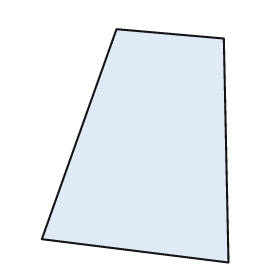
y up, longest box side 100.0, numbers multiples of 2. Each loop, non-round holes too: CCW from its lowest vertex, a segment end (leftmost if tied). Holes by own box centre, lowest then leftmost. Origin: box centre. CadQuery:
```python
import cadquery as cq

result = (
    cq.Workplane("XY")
    .moveTo(40.0, -50.0)
    .lineTo(38.0, 46.0)
    .lineTo(-8.0, 50.0)
    .lineTo(-40.0, -40.0)
    .close()
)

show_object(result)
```